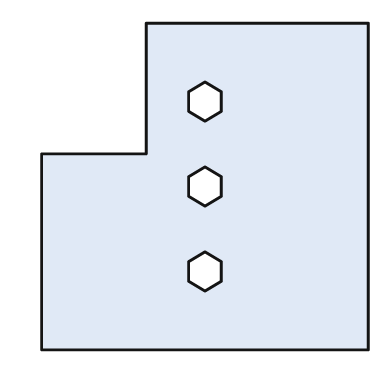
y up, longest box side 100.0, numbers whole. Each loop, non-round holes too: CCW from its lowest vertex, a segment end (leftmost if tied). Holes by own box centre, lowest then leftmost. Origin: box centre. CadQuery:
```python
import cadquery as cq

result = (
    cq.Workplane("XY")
    .moveTo(-50.0, -50.0)
    .lineTo(50.0, -50.0)
    .lineTo(50.0, 50.0)
    .lineTo(-18.0, 50.0)
    .lineTo(-18.0, 10.0)
    .lineTo(-50.0, 10.0)
    .close()
    .moveTo(0.0, -32.0)
    .lineTo(5.0, -29.0)
    .lineTo(5.0, -23.0)
    .lineTo(0.0, -20.0)
    .lineTo(-5.0, -23.0)
    .lineTo(-5.0, -29.0)
    .close()
    .moveTo(0.0, -6.0)
    .lineTo(5.0, -3.0)
    .lineTo(5.0, 3.0)
    .lineTo(0.0, 6.0)
    .lineTo(-5.0, 3.0)
    .lineTo(-5.0, -3.0)
    .close()
    .moveTo(0.0, 20.0)
    .lineTo(5.0, 23.0)
    .lineTo(5.0, 29.0)
    .lineTo(0.0, 32.0)
    .lineTo(-5.0, 29.0)
    .lineTo(-5.0, 23.0)
    .close()
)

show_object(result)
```